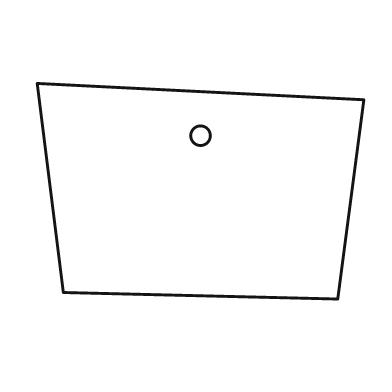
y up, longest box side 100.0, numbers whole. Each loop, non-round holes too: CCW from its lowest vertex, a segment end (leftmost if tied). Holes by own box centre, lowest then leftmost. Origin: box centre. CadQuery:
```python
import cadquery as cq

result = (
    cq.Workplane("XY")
    .moveTo(42.0, -33.0)
    .lineTo(50.0, 28.0)
    .lineTo(-50.0, 33.0)
    .lineTo(-42.0, -31.0)
    .close()
    .moveTo(0.0, 17.0)
    .circle(3.0)
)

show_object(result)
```